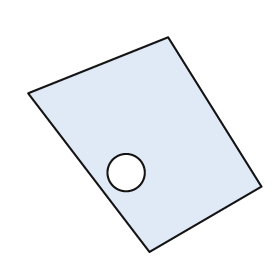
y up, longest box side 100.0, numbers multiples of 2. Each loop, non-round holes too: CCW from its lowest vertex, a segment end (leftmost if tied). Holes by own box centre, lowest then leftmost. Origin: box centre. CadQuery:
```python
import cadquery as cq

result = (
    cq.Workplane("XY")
    .moveTo(2.0, -46.0)
    .lineTo(50.0, -18.0)
    .lineTo(10.0, 46.0)
    .lineTo(-50.0, 22.0)
    .close()
    .moveTo(-8.0, -12.0)
    .circle(8.0)
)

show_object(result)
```